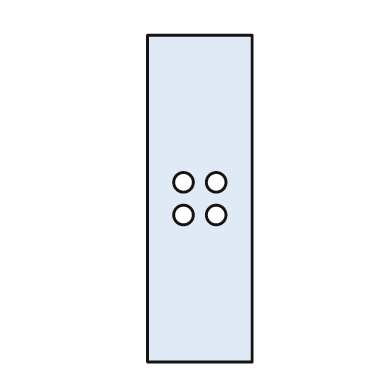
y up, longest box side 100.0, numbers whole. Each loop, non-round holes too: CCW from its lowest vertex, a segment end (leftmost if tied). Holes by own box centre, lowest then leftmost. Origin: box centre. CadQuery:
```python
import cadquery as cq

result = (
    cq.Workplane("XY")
    .moveTo(-16.0, -50.0)
    .lineTo(16.0, -50.0)
    .lineTo(16.0, 50.0)
    .lineTo(-16.0, 50.0)
    .close()
    .moveTo(-5.0, -5.0)
    .circle(3.0)
    .moveTo(5.0, -5.0)
    .circle(3.0)
    .moveTo(-5.0, 5.0)
    .circle(3.0)
    .moveTo(5.0, 5.0)
    .circle(3.0)
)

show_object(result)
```